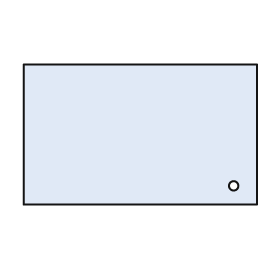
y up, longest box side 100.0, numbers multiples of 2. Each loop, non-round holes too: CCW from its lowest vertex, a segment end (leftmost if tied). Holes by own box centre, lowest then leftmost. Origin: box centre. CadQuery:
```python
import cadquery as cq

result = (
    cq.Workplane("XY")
    .moveTo(-50.0, -30.0)
    .lineTo(50.0, -30.0)
    .lineTo(50.0, 30.0)
    .lineTo(-50.0, 30.0)
    .close()
    .moveTo(40.0, -22.0)
    .circle(2.0)
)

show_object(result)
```